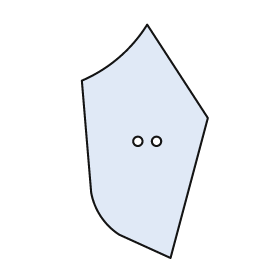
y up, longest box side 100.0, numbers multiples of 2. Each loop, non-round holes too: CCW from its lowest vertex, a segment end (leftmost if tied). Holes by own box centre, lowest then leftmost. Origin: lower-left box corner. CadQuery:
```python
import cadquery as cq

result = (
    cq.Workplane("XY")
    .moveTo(38.0, 0.0)
    .lineTo(54.0, 60.0)
    .lineTo(28.0, 100.0)
    .threePointArc((16.0, 86.0), (0.0, 76.0))
    .lineTo(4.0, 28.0)
    .threePointArc((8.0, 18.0), (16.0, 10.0))
    .close()
    .moveTo(24.0, 50.0)
    .circle(2.0)
    .moveTo(32.0, 50.0)
    .circle(2.0)
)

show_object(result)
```